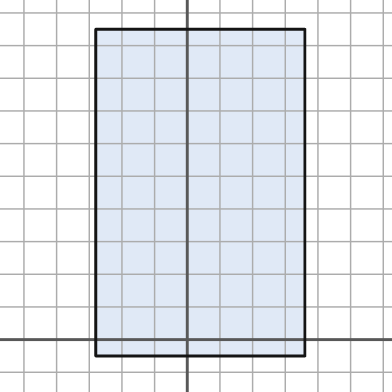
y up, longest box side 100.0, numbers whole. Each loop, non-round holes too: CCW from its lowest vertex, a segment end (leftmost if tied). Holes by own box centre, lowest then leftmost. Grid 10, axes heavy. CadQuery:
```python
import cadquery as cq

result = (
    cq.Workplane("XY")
    .moveTo(-28.0, -5.0)
    .lineTo(36.0, -5.0)
    .lineTo(36.0, 95.0)
    .lineTo(-28.0, 95.0)
    .close()
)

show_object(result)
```